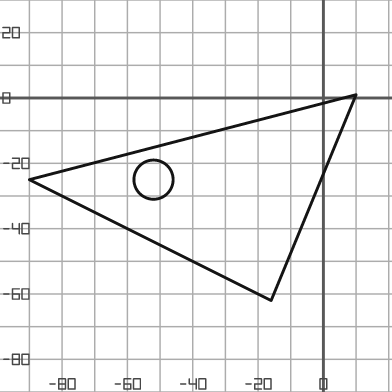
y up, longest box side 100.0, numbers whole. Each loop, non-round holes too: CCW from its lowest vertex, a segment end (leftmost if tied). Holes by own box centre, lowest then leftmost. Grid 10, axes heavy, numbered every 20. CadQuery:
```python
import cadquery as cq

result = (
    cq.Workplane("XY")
    .moveTo(-16.0, -62.0)
    .lineTo(10.0, 1.0)
    .lineTo(-90.0, -25.0)
    .close()
    .moveTo(-52.0, -25.0)
    .circle(6.0)
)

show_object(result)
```